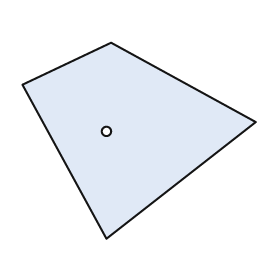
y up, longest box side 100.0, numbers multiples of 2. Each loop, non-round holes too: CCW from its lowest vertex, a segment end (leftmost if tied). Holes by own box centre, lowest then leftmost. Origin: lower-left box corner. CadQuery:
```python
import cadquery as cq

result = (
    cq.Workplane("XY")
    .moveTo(36.0, 0.0)
    .lineTo(100.0, 50.0)
    .lineTo(38.0, 84.0)
    .lineTo(0.0, 66.0)
    .close()
    .moveTo(36.0, 46.0)
    .circle(2.0)
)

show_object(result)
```